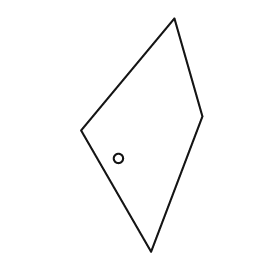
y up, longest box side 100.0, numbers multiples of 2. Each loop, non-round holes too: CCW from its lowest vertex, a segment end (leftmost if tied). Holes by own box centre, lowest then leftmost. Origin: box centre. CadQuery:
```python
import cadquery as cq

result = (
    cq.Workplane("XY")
    .moveTo(4.0, -50.0)
    .lineTo(26.0, 8.0)
    .lineTo(14.0, 50.0)
    .lineTo(-26.0, 2.0)
    .close()
    .moveTo(-10.0, -10.0)
    .circle(2.0)
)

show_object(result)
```